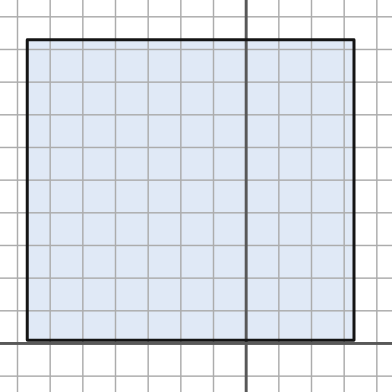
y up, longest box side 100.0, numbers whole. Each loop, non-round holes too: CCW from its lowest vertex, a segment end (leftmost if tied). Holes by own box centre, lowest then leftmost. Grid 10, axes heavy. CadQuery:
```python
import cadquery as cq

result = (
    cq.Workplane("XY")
    .moveTo(-67.0, 1.0)
    .lineTo(33.0, 1.0)
    .lineTo(33.0, 93.0)
    .lineTo(-67.0, 93.0)
    .close()
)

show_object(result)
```